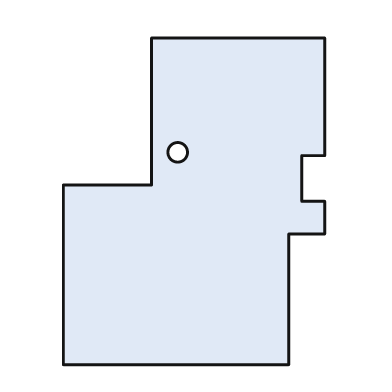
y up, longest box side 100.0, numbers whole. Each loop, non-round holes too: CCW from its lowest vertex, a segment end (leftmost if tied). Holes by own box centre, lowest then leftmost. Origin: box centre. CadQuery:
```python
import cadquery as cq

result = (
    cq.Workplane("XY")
    .moveTo(-40.0, -50.0)
    .lineTo(29.0, -50.0)
    .lineTo(29.0, -10.0)
    .lineTo(40.0, -10.0)
    .lineTo(40.0, 0.0)
    .lineTo(33.0, 0.0)
    .lineTo(33.0, 14.0)
    .lineTo(40.0, 14.0)
    .lineTo(40.0, 50.0)
    .lineTo(-13.0, 50.0)
    .lineTo(-13.0, 5.0)
    .lineTo(-40.0, 5.0)
    .close()
    .moveTo(-5.0, 15.0)
    .circle(3.0)
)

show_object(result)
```